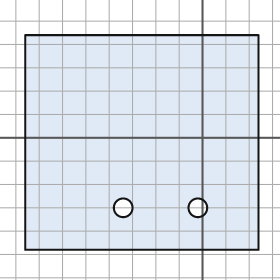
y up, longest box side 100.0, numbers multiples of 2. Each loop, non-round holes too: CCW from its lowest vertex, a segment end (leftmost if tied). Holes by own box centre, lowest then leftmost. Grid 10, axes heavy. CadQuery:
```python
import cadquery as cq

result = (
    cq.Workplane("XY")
    .moveTo(-76.0, -48.0)
    .lineTo(24.0, -48.0)
    .lineTo(24.0, 44.0)
    .lineTo(-76.0, 44.0)
    .close()
    .moveTo(-34.0, -30.0)
    .circle(4.0)
    .moveTo(-2.0, -30.0)
    .circle(4.0)
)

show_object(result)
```